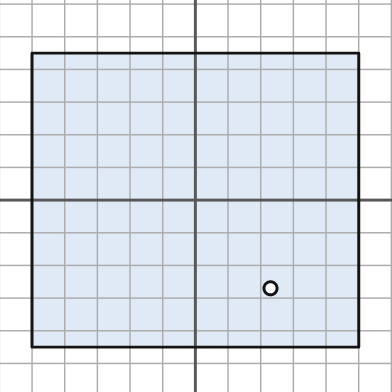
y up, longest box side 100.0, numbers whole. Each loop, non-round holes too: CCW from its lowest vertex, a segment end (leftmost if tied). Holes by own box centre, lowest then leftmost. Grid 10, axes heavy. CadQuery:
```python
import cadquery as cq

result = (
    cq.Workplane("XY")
    .moveTo(-50.0, -45.0)
    .lineTo(50.0, -45.0)
    .lineTo(50.0, 45.0)
    .lineTo(-50.0, 45.0)
    .close()
    .moveTo(23.0, -27.0)
    .circle(2.0)
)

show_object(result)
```